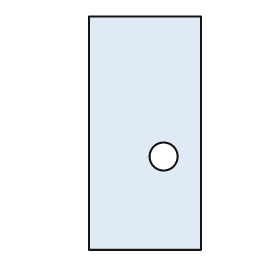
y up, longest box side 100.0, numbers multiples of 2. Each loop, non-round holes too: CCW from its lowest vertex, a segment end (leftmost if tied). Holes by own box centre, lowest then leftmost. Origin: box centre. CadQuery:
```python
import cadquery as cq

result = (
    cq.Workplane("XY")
    .moveTo(-24.0, -50.0)
    .lineTo(24.0, -50.0)
    .lineTo(24.0, 50.0)
    .lineTo(-24.0, 50.0)
    .close()
    .moveTo(8.0, -10.0)
    .circle(6.0)
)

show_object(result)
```